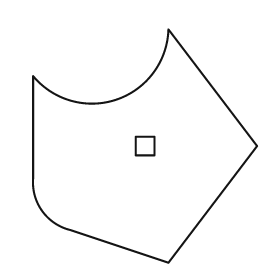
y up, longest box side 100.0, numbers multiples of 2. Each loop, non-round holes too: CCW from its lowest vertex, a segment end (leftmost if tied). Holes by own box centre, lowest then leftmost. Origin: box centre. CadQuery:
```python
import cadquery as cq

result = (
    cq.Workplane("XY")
    .moveTo(10.0, -50.0)
    .lineTo(48.0, 0.0)
    .lineTo(10.0, 50.0)
    .threePointArc((-12.0, 20.0), (-48.0, 30.0))
    .lineTo(-48.0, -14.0)
    .threePointArc((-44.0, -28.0), (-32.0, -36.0))
    .close()
    .moveTo(-4.0, -4.0)
    .lineTo(4.0, -4.0)
    .lineTo(4.0, 4.0)
    .lineTo(-4.0, 4.0)
    .close()
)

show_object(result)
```